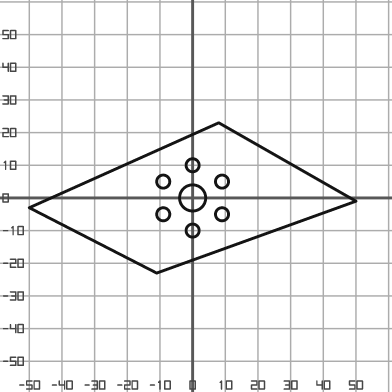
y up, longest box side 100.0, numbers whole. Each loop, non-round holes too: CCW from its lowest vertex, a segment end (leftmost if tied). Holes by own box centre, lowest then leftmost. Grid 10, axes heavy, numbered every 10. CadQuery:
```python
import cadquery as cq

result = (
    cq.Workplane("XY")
    .moveTo(-11.0, -23.0)
    .lineTo(50.0, -1.0)
    .lineTo(8.0, 23.0)
    .lineTo(-50.0, -3.0)
    .close()
    .moveTo(0.0, -10.0)
    .circle(2.0)
    .moveTo(-9.0, -5.0)
    .circle(2.0)
    .moveTo(9.0, -5.0)
    .circle(2.0)
    .moveTo(0.0, 0.0)
    .circle(4.0)
    .moveTo(-9.0, 5.0)
    .circle(2.0)
    .moveTo(9.0, 5.0)
    .circle(2.0)
    .moveTo(0.0, 10.0)
    .circle(2.0)
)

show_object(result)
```